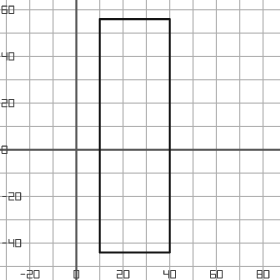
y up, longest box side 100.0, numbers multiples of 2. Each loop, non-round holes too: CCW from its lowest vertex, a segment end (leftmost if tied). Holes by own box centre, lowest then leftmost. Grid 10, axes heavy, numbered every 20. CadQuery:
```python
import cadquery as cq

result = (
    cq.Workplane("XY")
    .moveTo(10.0, -44.0)
    .lineTo(40.0, -44.0)
    .lineTo(40.0, 56.0)
    .lineTo(10.0, 56.0)
    .close()
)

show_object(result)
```